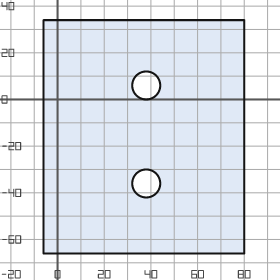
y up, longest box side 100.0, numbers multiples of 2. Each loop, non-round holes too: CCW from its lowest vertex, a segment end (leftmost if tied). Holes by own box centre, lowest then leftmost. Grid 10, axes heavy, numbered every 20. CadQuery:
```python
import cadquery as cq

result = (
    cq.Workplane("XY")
    .moveTo(-6.0, -66.0)
    .lineTo(80.0, -66.0)
    .lineTo(80.0, 34.0)
    .lineTo(-6.0, 34.0)
    .close()
    .moveTo(38.0, -36.0)
    .circle(6.0)
    .moveTo(38.0, 6.0)
    .circle(6.0)
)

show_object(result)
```